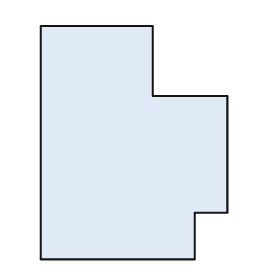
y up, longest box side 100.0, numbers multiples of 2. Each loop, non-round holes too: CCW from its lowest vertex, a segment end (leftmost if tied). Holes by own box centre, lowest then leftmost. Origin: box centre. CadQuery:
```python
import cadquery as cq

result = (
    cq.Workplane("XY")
    .moveTo(-40.0, -50.0)
    .lineTo(26.0, -50.0)
    .lineTo(26.0, -30.0)
    .lineTo(40.0, -30.0)
    .lineTo(40.0, 20.0)
    .lineTo(8.0, 20.0)
    .lineTo(8.0, 50.0)
    .lineTo(-40.0, 50.0)
    .close()
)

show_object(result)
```